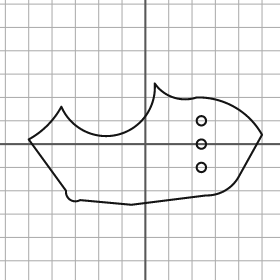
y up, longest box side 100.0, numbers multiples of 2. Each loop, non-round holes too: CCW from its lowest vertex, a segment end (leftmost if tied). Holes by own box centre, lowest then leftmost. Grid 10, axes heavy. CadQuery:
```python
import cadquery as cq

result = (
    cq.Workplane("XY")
    .moveTo(-6.0, -26.0)
    .lineTo(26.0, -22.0)
    .threePointArc((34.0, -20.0), (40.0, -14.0))
    .lineTo(50.0, 4.0)
    .threePointArc((38.0, 16.0), (22.0, 20.0))
    .threePointArc((12.0, 20.0), (4.0, 26.0))
    .threePointArc((-12.0, 4.0), (-36.0, 16.0))
    .threePointArc((-42.0, 8.0), (-50.0, 2.0))
    .lineTo(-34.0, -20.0)
    .threePointArc((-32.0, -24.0), (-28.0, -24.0))
    .close()
    .moveTo(24.0, -10.0)
    .circle(2.0)
    .moveTo(24.0, 0.0)
    .circle(2.0)
    .moveTo(24.0, 10.0)
    .circle(2.0)
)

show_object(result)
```